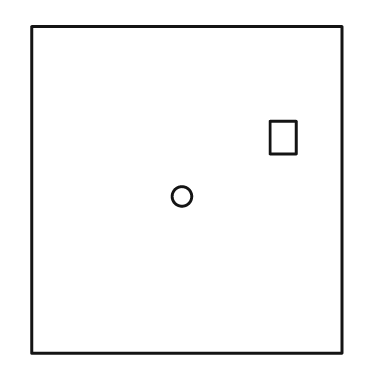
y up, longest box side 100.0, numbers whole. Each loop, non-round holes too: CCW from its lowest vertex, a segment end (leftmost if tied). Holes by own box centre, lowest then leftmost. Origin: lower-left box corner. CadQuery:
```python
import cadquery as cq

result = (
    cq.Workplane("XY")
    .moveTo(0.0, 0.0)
    .lineTo(95.0, 0.0)
    .lineTo(95.0, 100.0)
    .lineTo(0.0, 100.0)
    .close()
    .moveTo(46.0, 48.0)
    .circle(3.0)
    .moveTo(73.0, 61.0)
    .lineTo(81.0, 61.0)
    .lineTo(81.0, 71.0)
    .lineTo(73.0, 71.0)
    .close()
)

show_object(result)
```